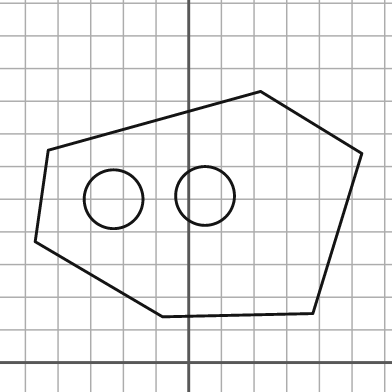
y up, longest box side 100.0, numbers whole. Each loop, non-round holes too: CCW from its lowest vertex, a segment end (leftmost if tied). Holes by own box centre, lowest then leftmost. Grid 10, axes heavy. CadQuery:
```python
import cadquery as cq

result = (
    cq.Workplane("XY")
    .moveTo(-8.0, 14.0)
    .lineTo(38.0, 15.0)
    .lineTo(53.0, 64.0)
    .lineTo(22.0, 83.0)
    .lineTo(-43.0, 65.0)
    .lineTo(-47.0, 37.0)
    .close()
    .moveTo(-23.0, 50.0)
    .circle(9.0)
    .moveTo(5.0, 51.0)
    .circle(9.0)
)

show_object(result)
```